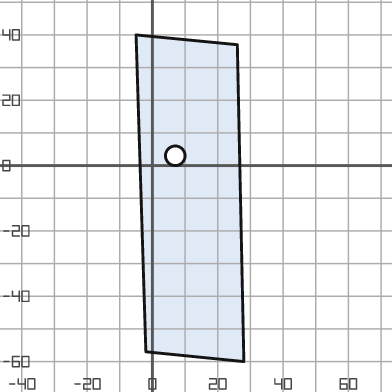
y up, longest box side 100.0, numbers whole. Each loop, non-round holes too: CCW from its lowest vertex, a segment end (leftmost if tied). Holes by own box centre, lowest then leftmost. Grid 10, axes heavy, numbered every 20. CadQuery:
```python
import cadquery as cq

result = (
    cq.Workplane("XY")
    .moveTo(28.0, -60.0)
    .lineTo(26.0, 37.0)
    .lineTo(-5.0, 40.0)
    .lineTo(-2.0, -57.0)
    .close()
    .moveTo(7.0, 3.0)
    .circle(3.0)
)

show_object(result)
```